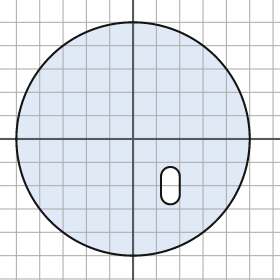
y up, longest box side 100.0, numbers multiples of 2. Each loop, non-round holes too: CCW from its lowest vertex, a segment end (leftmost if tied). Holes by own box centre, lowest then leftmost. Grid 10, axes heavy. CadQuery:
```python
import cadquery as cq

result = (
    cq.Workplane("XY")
    .moveTo(0.0, 0.0)
    .circle(50.0)
    .moveTo(12.0, -24.0)
    .threePointArc((16.0, -28.0), (20.0, -24.0))
    .lineTo(20.0, -16.0)
    .threePointArc((16.0, -12.0), (12.0, -16.0))
    .close()
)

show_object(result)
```